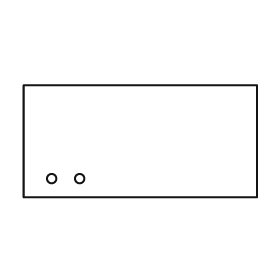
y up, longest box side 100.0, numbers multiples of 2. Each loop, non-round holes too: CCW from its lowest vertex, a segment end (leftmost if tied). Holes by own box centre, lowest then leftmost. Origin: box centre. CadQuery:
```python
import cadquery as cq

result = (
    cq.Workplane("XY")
    .moveTo(-50.0, -24.0)
    .lineTo(50.0, -24.0)
    .lineTo(50.0, 24.0)
    .lineTo(-50.0, 24.0)
    .close()
    .moveTo(-38.0, -16.0)
    .circle(2.0)
    .moveTo(-26.0, -16.0)
    .circle(2.0)
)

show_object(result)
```